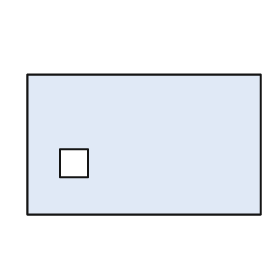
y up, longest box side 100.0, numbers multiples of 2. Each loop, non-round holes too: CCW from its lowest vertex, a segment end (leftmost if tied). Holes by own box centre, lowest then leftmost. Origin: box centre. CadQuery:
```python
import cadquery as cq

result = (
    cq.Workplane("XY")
    .moveTo(-50.0, -30.0)
    .lineTo(50.0, -30.0)
    .lineTo(50.0, 30.0)
    .lineTo(-50.0, 30.0)
    .close()
    .moveTo(-36.0, -14.0)
    .lineTo(-24.0, -14.0)
    .lineTo(-24.0, -2.0)
    .lineTo(-36.0, -2.0)
    .close()
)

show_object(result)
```